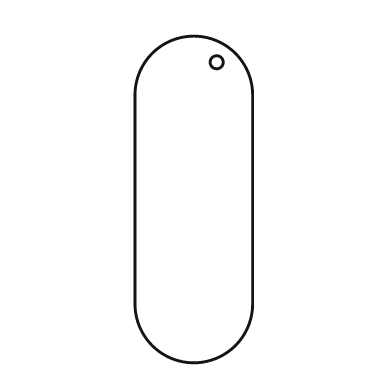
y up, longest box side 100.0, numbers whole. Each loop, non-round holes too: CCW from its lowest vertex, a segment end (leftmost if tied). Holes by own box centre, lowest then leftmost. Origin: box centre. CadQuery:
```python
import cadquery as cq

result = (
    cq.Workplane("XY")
    .moveTo(-18.0, -32.0)
    .threePointArc((0.0, -50.0), (18.0, -32.0))
    .lineTo(18.0, 32.0)
    .threePointArc((0.0, 50.0), (-18.0, 32.0))
    .close()
    .moveTo(7.0, 42.0)
    .circle(2.0)
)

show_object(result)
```